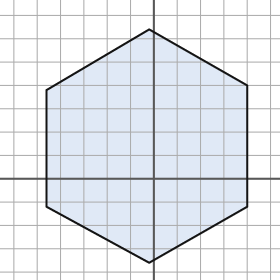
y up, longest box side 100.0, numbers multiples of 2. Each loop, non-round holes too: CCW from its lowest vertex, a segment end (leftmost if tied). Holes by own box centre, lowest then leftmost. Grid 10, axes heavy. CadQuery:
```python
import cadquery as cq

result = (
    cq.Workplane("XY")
    .moveTo(-2.0, -36.0)
    .lineTo(40.0, -12.0)
    .lineTo(40.0, 40.0)
    .lineTo(-2.0, 64.0)
    .lineTo(-46.0, 38.0)
    .lineTo(-46.0, -12.0)
    .close()
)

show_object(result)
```